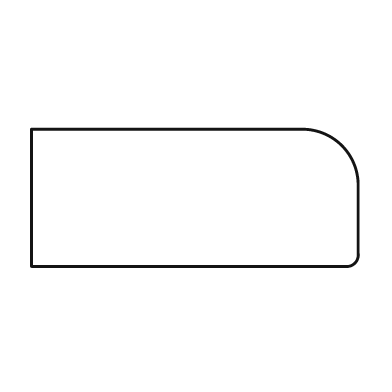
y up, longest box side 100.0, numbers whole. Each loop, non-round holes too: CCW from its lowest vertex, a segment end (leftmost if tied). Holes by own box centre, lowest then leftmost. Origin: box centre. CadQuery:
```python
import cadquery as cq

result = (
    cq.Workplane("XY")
    .moveTo(-50.0, -21.0)
    .lineTo(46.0, -21.0)
    .threePointArc((49.0, -20.0), (50.0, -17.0))
    .lineTo(50.0, 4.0)
    .threePointArc((45.0, 16.0), (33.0, 21.0))
    .lineTo(-50.0, 21.0)
    .close()
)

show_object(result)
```